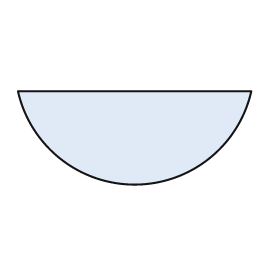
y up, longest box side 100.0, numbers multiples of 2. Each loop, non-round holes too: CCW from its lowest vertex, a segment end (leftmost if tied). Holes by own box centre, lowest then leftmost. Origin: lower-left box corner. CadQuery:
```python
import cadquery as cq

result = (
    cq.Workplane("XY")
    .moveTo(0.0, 40.0)
    .threePointArc((50.0, 0.0), (100.0, 40.0))
    .close()
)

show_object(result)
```